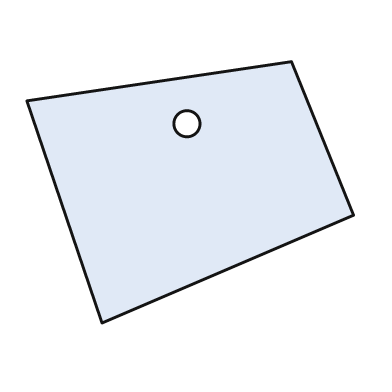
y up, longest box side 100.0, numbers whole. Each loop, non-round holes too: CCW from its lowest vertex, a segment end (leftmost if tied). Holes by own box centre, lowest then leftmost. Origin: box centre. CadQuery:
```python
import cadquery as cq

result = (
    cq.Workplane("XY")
    .moveTo(-27.0, -40.0)
    .lineTo(50.0, -7.0)
    .lineTo(31.0, 40.0)
    .lineTo(-50.0, 28.0)
    .close()
    .moveTo(-1.0, 21.0)
    .circle(4.0)
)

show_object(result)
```